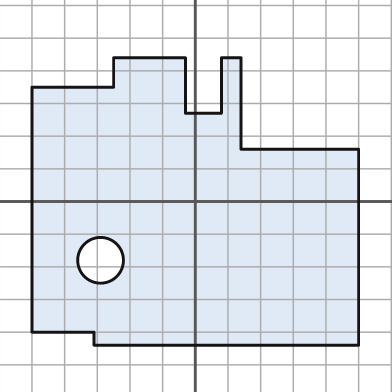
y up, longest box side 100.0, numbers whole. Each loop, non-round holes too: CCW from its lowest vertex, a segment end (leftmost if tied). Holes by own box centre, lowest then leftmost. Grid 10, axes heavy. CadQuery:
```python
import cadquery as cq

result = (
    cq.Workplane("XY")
    .moveTo(-31.0, -44.0)
    .lineTo(50.0, -44.0)
    .lineTo(50.0, 16.0)
    .lineTo(14.0, 16.0)
    .lineTo(14.0, 44.0)
    .lineTo(8.0, 44.0)
    .lineTo(8.0, 27.0)
    .lineTo(-3.0, 27.0)
    .lineTo(-3.0, 44.0)
    .lineTo(-25.0, 44.0)
    .lineTo(-25.0, 35.0)
    .lineTo(-50.0, 35.0)
    .lineTo(-50.0, -40.0)
    .lineTo(-31.0, -40.0)
    .close()
    .moveTo(-29.0, -18.0)
    .circle(7.0)
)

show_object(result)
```